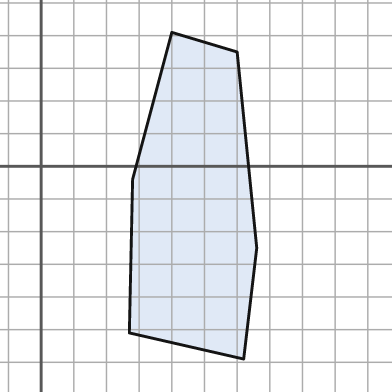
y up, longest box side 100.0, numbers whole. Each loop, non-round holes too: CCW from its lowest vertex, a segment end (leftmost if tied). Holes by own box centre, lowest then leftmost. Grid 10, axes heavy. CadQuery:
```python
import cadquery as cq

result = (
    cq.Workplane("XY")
    .moveTo(62.0, -59.0)
    .lineTo(66.0, -25.0)
    .lineTo(60.0, 35.0)
    .lineTo(40.0, 41.0)
    .lineTo(28.0, -4.0)
    .lineTo(27.0, -51.0)
    .close()
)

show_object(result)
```